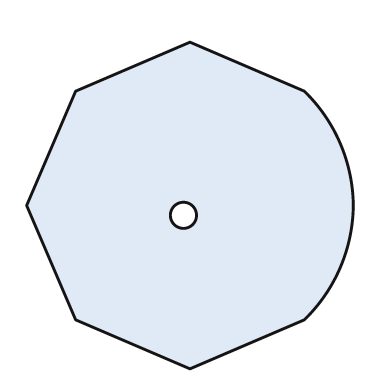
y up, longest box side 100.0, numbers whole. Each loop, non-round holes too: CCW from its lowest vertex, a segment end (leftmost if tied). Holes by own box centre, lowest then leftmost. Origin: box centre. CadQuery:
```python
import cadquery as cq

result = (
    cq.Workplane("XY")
    .moveTo(0.0, -50.0)
    .lineTo(35.0, -35.0)
    .threePointArc((46.0, -19.0), (50.0, 0.0))
    .threePointArc((46.0, 19.0), (35.0, 35.0))
    .lineTo(0.0, 50.0)
    .lineTo(-35.0, 35.0)
    .lineTo(-50.0, 0.0)
    .lineTo(-35.0, -35.0)
    .close()
    .moveTo(-2.0, -3.0)
    .circle(4.0)
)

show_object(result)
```